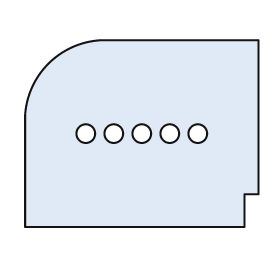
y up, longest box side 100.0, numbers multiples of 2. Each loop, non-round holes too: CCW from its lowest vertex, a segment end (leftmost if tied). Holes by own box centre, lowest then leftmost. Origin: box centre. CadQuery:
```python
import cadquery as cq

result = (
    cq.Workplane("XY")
    .moveTo(-50.0, -40.0)
    .lineTo(44.0, -40.0)
    .lineTo(44.0, -26.0)
    .lineTo(50.0, -26.0)
    .lineTo(50.0, 40.0)
    .lineTo(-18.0, 40.0)
    .threePointArc((-40.0, 30.0), (-50.0, 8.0))
    .close()
    .moveTo(-24.0, 0.0)
    .circle(4.0)
    .moveTo(-12.0, 0.0)
    .circle(4.0)
    .moveTo(0.0, 0.0)
    .circle(4.0)
    .moveTo(12.0, 0.0)
    .circle(4.0)
    .moveTo(24.0, 0.0)
    .circle(4.0)
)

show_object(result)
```